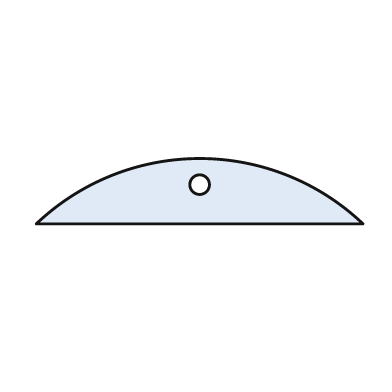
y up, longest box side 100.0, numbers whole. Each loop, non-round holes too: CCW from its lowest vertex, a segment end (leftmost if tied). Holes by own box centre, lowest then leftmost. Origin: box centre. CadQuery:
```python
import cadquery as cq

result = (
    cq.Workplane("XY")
    .moveTo(-50.0, -10.0)
    .lineTo(50.0, -10.0)
    .threePointArc((0.0, 10.0), (-50.0, -10.0))
    .close()
    .moveTo(0.0, 2.0)
    .circle(3.0)
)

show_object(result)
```